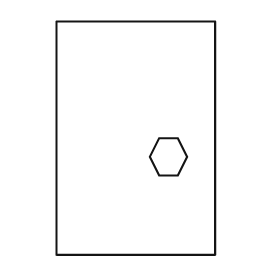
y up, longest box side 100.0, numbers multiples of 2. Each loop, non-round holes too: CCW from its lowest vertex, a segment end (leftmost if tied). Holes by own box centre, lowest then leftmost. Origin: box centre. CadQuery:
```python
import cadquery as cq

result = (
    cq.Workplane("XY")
    .moveTo(-34.0, -50.0)
    .lineTo(34.0, -50.0)
    .lineTo(34.0, 50.0)
    .lineTo(-34.0, 50.0)
    .close()
    .moveTo(10.0, -16.0)
    .lineTo(18.0, -16.0)
    .lineTo(22.0, -8.0)
    .lineTo(18.0, 0.0)
    .lineTo(10.0, 0.0)
    .lineTo(6.0, -8.0)
    .close()
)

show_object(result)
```